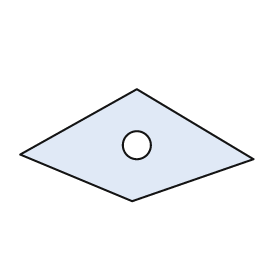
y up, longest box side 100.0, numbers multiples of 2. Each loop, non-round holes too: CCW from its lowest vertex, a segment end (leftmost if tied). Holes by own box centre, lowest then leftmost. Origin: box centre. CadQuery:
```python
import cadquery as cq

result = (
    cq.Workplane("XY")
    .moveTo(-2.0, -24.0)
    .lineTo(50.0, -6.0)
    .lineTo(0.0, 24.0)
    .lineTo(-50.0, -4.0)
    .close()
    .moveTo(0.0, 0.0)
    .circle(6.0)
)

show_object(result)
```